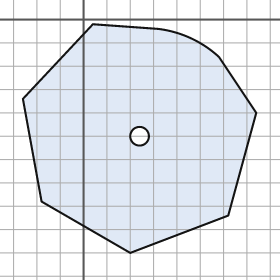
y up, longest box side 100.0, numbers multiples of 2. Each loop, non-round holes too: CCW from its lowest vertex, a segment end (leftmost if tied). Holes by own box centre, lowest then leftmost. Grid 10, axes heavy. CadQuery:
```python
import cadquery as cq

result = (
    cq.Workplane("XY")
    .moveTo(20.0, -100.0)
    .lineTo(62.0, -84.0)
    .lineTo(74.0, -40.0)
    .lineTo(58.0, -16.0)
    .threePointArc((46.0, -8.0), (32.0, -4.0))
    .lineTo(4.0, -2.0)
    .lineTo(-26.0, -34.0)
    .lineTo(-18.0, -78.0)
    .close()
    .moveTo(24.0, -50.0)
    .circle(4.0)
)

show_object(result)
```